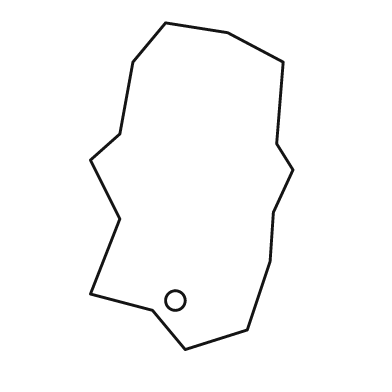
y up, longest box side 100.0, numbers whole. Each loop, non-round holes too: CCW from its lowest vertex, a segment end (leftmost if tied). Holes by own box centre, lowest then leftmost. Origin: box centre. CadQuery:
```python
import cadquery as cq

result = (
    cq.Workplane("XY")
    .moveTo(-2.0, -50.0)
    .lineTo(17.0, -44.0)
    .lineTo(24.0, -23.0)
    .lineTo(25.0, -8.0)
    .lineTo(31.0, 5.0)
    .lineTo(26.0, 13.0)
    .lineTo(28.0, 38.0)
    .lineTo(11.0, 47.0)
    .lineTo(-8.0, 50.0)
    .lineTo(-18.0, 38.0)
    .lineTo(-22.0, 16.0)
    .lineTo(-31.0, 8.0)
    .lineTo(-22.0, -10.0)
    .lineTo(-31.0, -33.0)
    .lineTo(-12.0, -38.0)
    .close()
    .moveTo(-5.0, -35.0)
    .circle(3.0)
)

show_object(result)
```